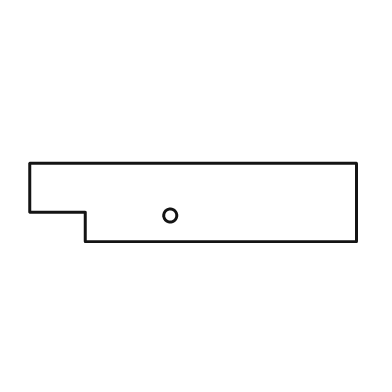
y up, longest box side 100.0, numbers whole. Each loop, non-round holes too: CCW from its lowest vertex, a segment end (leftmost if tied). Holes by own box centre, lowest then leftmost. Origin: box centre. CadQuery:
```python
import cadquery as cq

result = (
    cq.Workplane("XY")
    .moveTo(-33.0, -12.0)
    .lineTo(50.0, -12.0)
    .lineTo(50.0, 12.0)
    .lineTo(-50.0, 12.0)
    .lineTo(-50.0, -3.0)
    .lineTo(-33.0, -3.0)
    .close()
    .moveTo(-7.0, -4.0)
    .circle(2.0)
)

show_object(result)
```